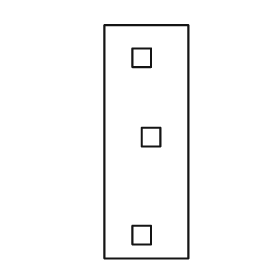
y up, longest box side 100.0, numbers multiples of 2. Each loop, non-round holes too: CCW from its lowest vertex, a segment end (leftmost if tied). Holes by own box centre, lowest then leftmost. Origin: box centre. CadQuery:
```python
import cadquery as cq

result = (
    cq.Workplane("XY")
    .moveTo(-18.0, -50.0)
    .lineTo(18.0, -50.0)
    .lineTo(18.0, 50.0)
    .lineTo(-18.0, 50.0)
    .close()
    .moveTo(-6.0, -44.0)
    .lineTo(2.0, -44.0)
    .lineTo(2.0, -36.0)
    .lineTo(-6.0, -36.0)
    .close()
    .moveTo(-2.0, -2.0)
    .lineTo(6.0, -2.0)
    .lineTo(6.0, 6.0)
    .lineTo(-2.0, 6.0)
    .close()
    .moveTo(-6.0, 32.0)
    .lineTo(2.0, 32.0)
    .lineTo(2.0, 40.0)
    .lineTo(-6.0, 40.0)
    .close()
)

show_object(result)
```